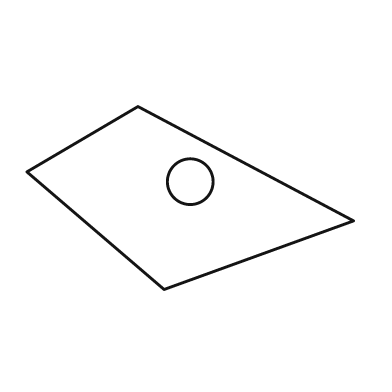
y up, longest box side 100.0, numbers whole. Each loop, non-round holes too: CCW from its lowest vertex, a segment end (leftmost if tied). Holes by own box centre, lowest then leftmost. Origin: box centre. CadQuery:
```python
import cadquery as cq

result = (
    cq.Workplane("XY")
    .moveTo(-8.0, -28.0)
    .lineTo(50.0, -7.0)
    .lineTo(-16.0, 28.0)
    .lineTo(-50.0, 8.0)
    .close()
    .moveTo(0.0, 5.0)
    .circle(7.0)
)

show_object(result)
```